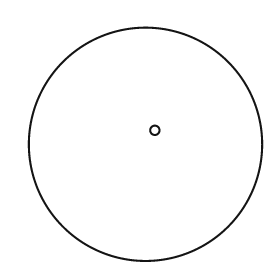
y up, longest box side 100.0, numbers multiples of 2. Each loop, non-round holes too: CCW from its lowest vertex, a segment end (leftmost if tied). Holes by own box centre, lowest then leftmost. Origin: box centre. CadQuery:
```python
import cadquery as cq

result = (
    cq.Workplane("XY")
    .moveTo(0.0, 0.0)
    .circle(50.0)
    .moveTo(4.0, 6.0)
    .circle(2.0)
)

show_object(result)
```